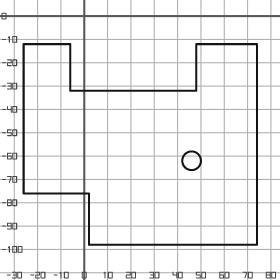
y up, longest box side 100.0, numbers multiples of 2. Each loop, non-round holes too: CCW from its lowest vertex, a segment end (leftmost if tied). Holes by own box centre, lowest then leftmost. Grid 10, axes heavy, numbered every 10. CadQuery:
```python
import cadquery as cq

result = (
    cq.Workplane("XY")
    .moveTo(2.0, -98.0)
    .lineTo(74.0, -98.0)
    .lineTo(74.0, -12.0)
    .lineTo(48.0, -12.0)
    .lineTo(48.0, -32.0)
    .lineTo(-6.0, -32.0)
    .lineTo(-6.0, -12.0)
    .lineTo(-26.0, -12.0)
    .lineTo(-26.0, -76.0)
    .lineTo(2.0, -76.0)
    .close()
    .moveTo(46.0, -62.0)
    .circle(4.0)
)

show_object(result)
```